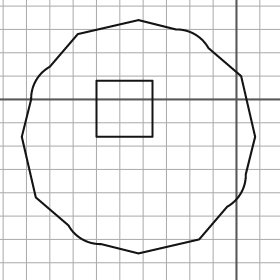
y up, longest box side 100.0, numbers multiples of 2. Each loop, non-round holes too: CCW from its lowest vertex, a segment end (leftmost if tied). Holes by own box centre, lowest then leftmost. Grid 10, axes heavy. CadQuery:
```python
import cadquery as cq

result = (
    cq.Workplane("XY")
    .moveTo(-42.0, -66.0)
    .lineTo(-16.0, -60.0)
    .lineTo(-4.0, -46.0)
    .threePointArc((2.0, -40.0), (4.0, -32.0))
    .lineTo(8.0, -16.0)
    .lineTo(2.0, 10.0)
    .lineTo(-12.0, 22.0)
    .threePointArc((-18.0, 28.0), (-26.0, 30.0))
    .lineTo(-42.0, 34.0)
    .lineTo(-68.0, 28.0)
    .lineTo(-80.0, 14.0)
    .threePointArc((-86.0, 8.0), (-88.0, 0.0))
    .lineTo(-92.0, -16.0)
    .lineTo(-86.0, -42.0)
    .lineTo(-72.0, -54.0)
    .threePointArc((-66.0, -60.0), (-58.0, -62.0))
    .close()
    .moveTo(-60.0, -16.0)
    .lineTo(-36.0, -16.0)
    .lineTo(-36.0, 8.0)
    .lineTo(-60.0, 8.0)
    .close()
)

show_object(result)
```